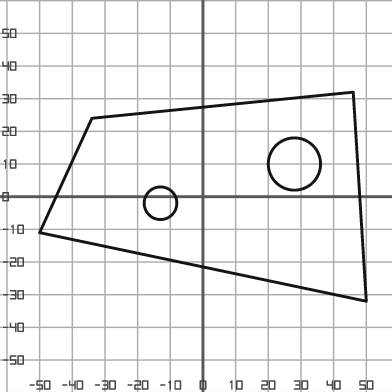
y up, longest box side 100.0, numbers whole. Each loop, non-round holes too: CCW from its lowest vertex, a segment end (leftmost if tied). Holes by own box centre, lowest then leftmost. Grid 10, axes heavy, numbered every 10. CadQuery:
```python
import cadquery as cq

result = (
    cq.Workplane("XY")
    .moveTo(50.0, -32.0)
    .lineTo(46.0, 32.0)
    .lineTo(-34.0, 24.0)
    .lineTo(-50.0, -11.0)
    .close()
    .moveTo(-13.0, -2.0)
    .circle(5.0)
    .moveTo(28.0, 10.0)
    .circle(8.0)
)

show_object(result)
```